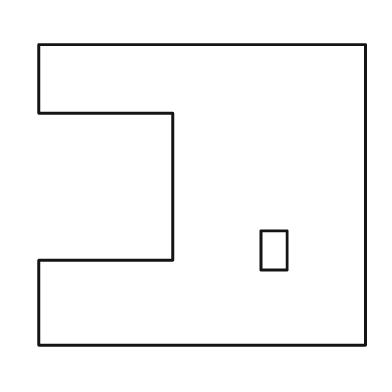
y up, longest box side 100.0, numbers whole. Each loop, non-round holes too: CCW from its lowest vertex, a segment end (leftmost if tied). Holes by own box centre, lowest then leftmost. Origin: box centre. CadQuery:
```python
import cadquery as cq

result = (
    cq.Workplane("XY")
    .moveTo(-50.0, -46.0)
    .lineTo(50.0, -46.0)
    .lineTo(50.0, 46.0)
    .lineTo(-50.0, 46.0)
    .lineTo(-50.0, 25.0)
    .lineTo(-9.0, 25.0)
    .lineTo(-9.0, -20.0)
    .lineTo(-50.0, -20.0)
    .close()
    .moveTo(18.0, -23.0)
    .lineTo(26.0, -23.0)
    .lineTo(26.0, -11.0)
    .lineTo(18.0, -11.0)
    .close()
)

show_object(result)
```